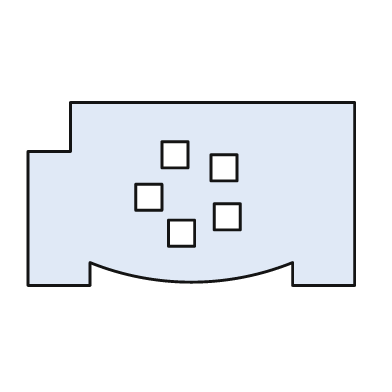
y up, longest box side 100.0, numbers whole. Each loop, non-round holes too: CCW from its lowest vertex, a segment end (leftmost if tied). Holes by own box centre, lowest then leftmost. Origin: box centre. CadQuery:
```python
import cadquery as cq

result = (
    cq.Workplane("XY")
    .moveTo(-50.0, -28.0)
    .lineTo(-31.0, -28.0)
    .lineTo(-31.0, -21.0)
    .threePointArc((0.0, -27.0), (31.0, -21.0))
    .lineTo(31.0, -28.0)
    .lineTo(50.0, -28.0)
    .lineTo(50.0, 28.0)
    .lineTo(-37.0, 28.0)
    .lineTo(-37.0, 13.0)
    .lineTo(-50.0, 13.0)
    .close()
    .moveTo(-7.0, -16.0)
    .lineTo(1.0, -16.0)
    .lineTo(1.0, -8.0)
    .lineTo(-7.0, -8.0)
    .close()
    .moveTo(7.0, -11.0)
    .lineTo(15.0, -11.0)
    .lineTo(15.0, -3.0)
    .lineTo(7.0, -3.0)
    .close()
    .moveTo(-17.0, -5.0)
    .lineTo(-9.0, -5.0)
    .lineTo(-9.0, 3.0)
    .lineTo(-17.0, 3.0)
    .close()
    .moveTo(6.0, 4.0)
    .lineTo(14.0, 4.0)
    .lineTo(14.0, 12.0)
    .lineTo(6.0, 12.0)
    .close()
    .moveTo(-9.0, 8.0)
    .lineTo(-1.0, 8.0)
    .lineTo(-1.0, 16.0)
    .lineTo(-9.0, 16.0)
    .close()
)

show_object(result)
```